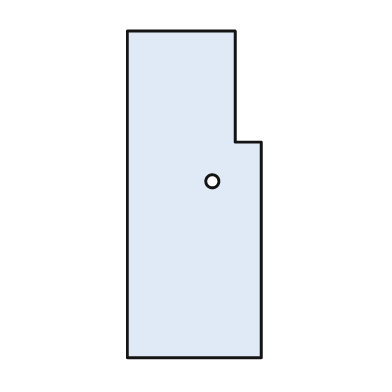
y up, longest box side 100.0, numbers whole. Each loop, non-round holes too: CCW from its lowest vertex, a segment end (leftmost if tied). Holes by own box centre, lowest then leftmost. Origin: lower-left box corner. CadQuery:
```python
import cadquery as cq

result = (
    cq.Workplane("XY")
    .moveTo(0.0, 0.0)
    .lineTo(41.0, 0.0)
    .lineTo(41.0, 66.0)
    .lineTo(33.0, 66.0)
    .lineTo(33.0, 100.0)
    .lineTo(0.0, 100.0)
    .close()
    .moveTo(26.0, 54.0)
    .circle(2.0)
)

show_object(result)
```